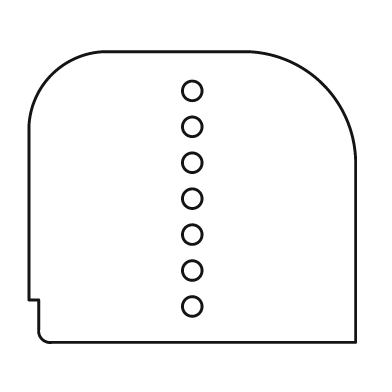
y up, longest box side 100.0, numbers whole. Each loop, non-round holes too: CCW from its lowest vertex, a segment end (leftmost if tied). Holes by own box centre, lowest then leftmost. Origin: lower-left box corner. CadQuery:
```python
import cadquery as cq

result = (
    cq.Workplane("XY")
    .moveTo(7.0, 0.0)
    .lineTo(100.0, 0.0)
    .lineTo(100.0, 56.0)
    .threePointArc((90.0, 79.0), (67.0, 89.0))
    .lineTo(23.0, 89.0)
    .threePointArc((7.0, 82.0), (0.0, 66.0))
    .lineTo(0.0, 13.0)
    .lineTo(3.0, 13.0)
    .lineTo(3.0, 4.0)
    .threePointArc((4.0, 1.0), (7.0, 0.0))
    .close()
    .moveTo(50.0, 11.0)
    .circle(3.0)
    .moveTo(50.0, 22.0)
    .circle(3.0)
    .moveTo(50.0, 33.0)
    .circle(3.0)
    .moveTo(50.0, 44.0)
    .circle(3.0)
    .moveTo(50.0, 55.0)
    .circle(3.0)
    .moveTo(50.0, 66.0)
    .circle(3.0)
    .moveTo(50.0, 77.0)
    .circle(3.0)
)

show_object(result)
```